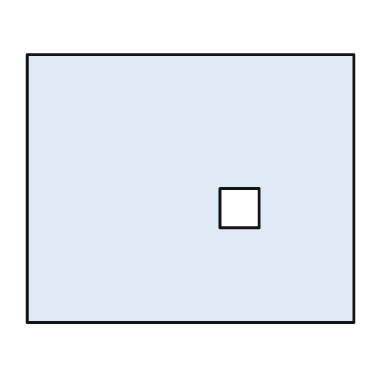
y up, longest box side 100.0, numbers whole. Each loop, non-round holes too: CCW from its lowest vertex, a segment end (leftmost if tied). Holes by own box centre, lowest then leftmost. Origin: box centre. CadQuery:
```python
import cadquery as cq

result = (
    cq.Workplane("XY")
    .moveTo(-50.0, -41.0)
    .lineTo(50.0, -41.0)
    .lineTo(50.0, 41.0)
    .lineTo(-50.0, 41.0)
    .close()
    .moveTo(9.0, -12.0)
    .lineTo(21.0, -12.0)
    .lineTo(21.0, 0.0)
    .lineTo(9.0, 0.0)
    .close()
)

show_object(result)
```